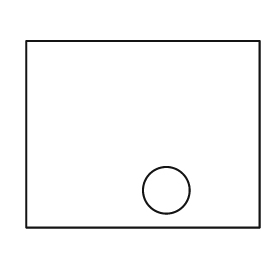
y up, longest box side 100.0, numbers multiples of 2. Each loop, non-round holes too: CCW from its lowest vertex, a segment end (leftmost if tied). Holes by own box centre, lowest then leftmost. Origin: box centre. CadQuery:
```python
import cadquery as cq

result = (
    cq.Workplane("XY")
    .moveTo(-50.0, -40.0)
    .lineTo(50.0, -40.0)
    .lineTo(50.0, 40.0)
    .lineTo(-50.0, 40.0)
    .close()
    .moveTo(10.0, -24.0)
    .circle(10.0)
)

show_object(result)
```